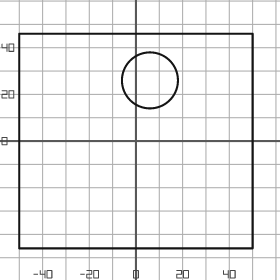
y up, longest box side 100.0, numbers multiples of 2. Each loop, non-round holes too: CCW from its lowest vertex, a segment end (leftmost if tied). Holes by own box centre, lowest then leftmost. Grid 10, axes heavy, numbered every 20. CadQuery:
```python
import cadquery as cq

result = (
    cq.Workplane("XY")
    .moveTo(-50.0, -46.0)
    .lineTo(50.0, -46.0)
    .lineTo(50.0, 46.0)
    .lineTo(-50.0, 46.0)
    .close()
    .moveTo(6.0, 26.0)
    .circle(12.0)
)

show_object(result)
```